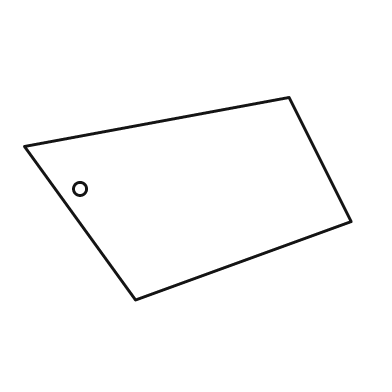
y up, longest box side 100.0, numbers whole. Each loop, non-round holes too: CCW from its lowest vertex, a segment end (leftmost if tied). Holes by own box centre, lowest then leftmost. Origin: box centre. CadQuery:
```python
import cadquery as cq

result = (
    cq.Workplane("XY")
    .moveTo(-16.0, -31.0)
    .lineTo(50.0, -7.0)
    .lineTo(31.0, 31.0)
    .lineTo(-50.0, 16.0)
    .close()
    .moveTo(-33.0, 3.0)
    .circle(2.0)
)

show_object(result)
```